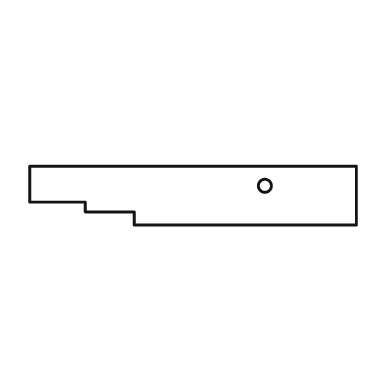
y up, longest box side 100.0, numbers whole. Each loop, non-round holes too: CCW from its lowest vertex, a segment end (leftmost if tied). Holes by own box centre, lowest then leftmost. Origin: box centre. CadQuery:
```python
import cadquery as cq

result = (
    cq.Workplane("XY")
    .moveTo(-18.0, -9.0)
    .lineTo(50.0, -9.0)
    .lineTo(50.0, 9.0)
    .lineTo(-50.0, 9.0)
    .lineTo(-50.0, -2.0)
    .lineTo(-33.0, -2.0)
    .lineTo(-33.0, -5.0)
    .lineTo(-18.0, -5.0)
    .close()
    .moveTo(22.0, 3.0)
    .circle(2.0)
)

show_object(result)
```